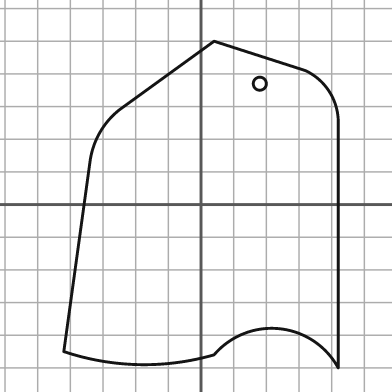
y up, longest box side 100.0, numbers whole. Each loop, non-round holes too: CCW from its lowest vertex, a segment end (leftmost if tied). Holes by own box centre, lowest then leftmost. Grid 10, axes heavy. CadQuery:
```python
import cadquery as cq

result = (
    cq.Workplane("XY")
    .moveTo(42.0, -50.0)
    .lineTo(42.0, 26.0)
    .threePointArc((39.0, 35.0), (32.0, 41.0))
    .lineTo(4.0, 50.0)
    .lineTo(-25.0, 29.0)
    .threePointArc((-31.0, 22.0), (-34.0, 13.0))
    .lineTo(-42.0, -45.0)
    .threePointArc((-19.0, -49.0), (4.0, -46.0))
    .threePointArc((24.0, -38.0), (42.0, -50.0))
    .close()
    .moveTo(18.0, 37.0)
    .circle(2.0)
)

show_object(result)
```